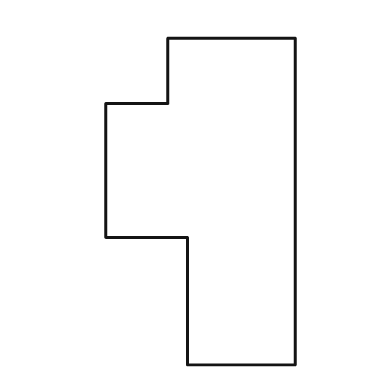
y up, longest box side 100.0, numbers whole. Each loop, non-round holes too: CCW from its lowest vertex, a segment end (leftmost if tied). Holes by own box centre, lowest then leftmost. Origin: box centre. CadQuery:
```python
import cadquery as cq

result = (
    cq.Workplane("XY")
    .moveTo(-4.0, -50.0)
    .lineTo(29.0, -50.0)
    .lineTo(29.0, 50.0)
    .lineTo(-10.0, 50.0)
    .lineTo(-10.0, 30.0)
    .lineTo(-29.0, 30.0)
    .lineTo(-29.0, -11.0)
    .lineTo(-4.0, -11.0)
    .close()
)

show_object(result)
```